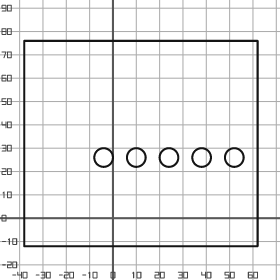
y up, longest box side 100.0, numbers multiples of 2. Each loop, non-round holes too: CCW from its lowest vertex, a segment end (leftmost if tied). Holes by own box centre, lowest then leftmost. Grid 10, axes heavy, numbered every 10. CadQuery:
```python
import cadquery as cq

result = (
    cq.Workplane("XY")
    .moveTo(-38.0, -12.0)
    .lineTo(62.0, -12.0)
    .lineTo(62.0, 76.0)
    .lineTo(-38.0, 76.0)
    .close()
    .moveTo(-4.0, 26.0)
    .circle(4.0)
    .moveTo(10.0, 26.0)
    .circle(4.0)
    .moveTo(24.0, 26.0)
    .circle(4.0)
    .moveTo(38.0, 26.0)
    .circle(4.0)
    .moveTo(52.0, 26.0)
    .circle(4.0)
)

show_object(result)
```